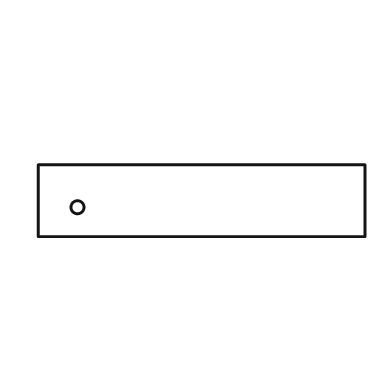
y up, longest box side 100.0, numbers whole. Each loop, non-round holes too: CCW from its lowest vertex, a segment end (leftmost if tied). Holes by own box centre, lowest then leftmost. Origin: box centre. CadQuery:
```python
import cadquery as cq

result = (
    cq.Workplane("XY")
    .moveTo(-50.0, -11.0)
    .lineTo(50.0, -11.0)
    .lineTo(50.0, 11.0)
    .lineTo(-50.0, 11.0)
    .close()
    .moveTo(-38.0, -2.0)
    .circle(2.0)
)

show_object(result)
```